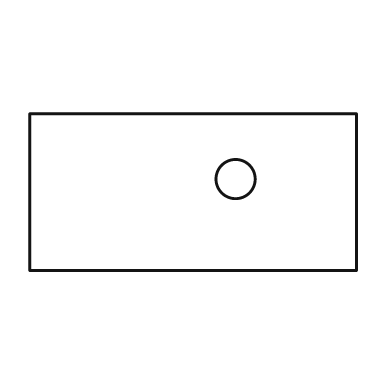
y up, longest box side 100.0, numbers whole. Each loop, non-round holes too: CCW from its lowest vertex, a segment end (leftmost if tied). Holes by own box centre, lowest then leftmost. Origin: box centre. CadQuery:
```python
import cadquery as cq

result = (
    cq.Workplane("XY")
    .moveTo(-50.0, -24.0)
    .lineTo(50.0, -24.0)
    .lineTo(50.0, 24.0)
    .lineTo(-50.0, 24.0)
    .close()
    .moveTo(13.0, 4.0)
    .circle(6.0)
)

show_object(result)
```